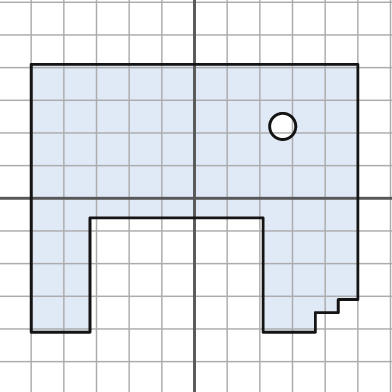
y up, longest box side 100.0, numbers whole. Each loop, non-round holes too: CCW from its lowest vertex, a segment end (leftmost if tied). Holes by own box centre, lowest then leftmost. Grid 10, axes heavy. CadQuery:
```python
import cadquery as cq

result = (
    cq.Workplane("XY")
    .moveTo(-50.0, -41.0)
    .lineTo(-32.0, -41.0)
    .lineTo(-32.0, -6.0)
    .lineTo(21.0, -6.0)
    .lineTo(21.0, -41.0)
    .lineTo(37.0, -41.0)
    .lineTo(37.0, -35.0)
    .lineTo(44.0, -35.0)
    .lineTo(44.0, -31.0)
    .lineTo(50.0, -31.0)
    .lineTo(50.0, 41.0)
    .lineTo(-50.0, 41.0)
    .close()
    .moveTo(27.0, 22.0)
    .circle(4.0)
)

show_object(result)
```